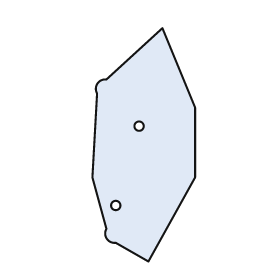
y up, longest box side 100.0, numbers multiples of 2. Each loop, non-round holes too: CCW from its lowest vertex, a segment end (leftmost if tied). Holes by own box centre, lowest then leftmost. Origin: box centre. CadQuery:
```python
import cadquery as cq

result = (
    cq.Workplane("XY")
    .moveTo(2.0, -50.0)
    .lineTo(22.0, -14.0)
    .lineTo(22.0, 16.0)
    .lineTo(8.0, 50.0)
    .lineTo(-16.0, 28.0)
    .threePointArc((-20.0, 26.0), (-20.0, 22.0))
    .lineTo(-22.0, -14.0)
    .lineTo(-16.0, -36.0)
    .threePointArc((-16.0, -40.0), (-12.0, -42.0))
    .close()
    .moveTo(-12.0, -26.0)
    .circle(2.0)
    .moveTo(-2.0, 8.0)
    .circle(2.0)
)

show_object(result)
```